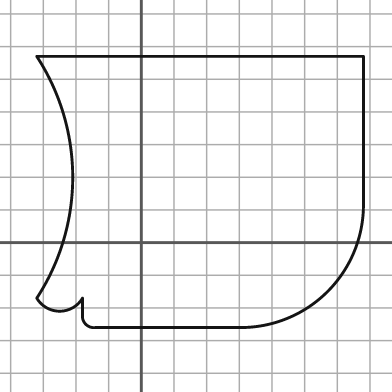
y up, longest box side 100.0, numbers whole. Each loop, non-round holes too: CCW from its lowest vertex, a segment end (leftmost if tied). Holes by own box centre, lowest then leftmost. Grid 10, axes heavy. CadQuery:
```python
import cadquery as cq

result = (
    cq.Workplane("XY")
    .moveTo(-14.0, -26.0)
    .lineTo(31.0, -26.0)
    .threePointArc((57.0, -15.0), (68.0, 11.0))
    .lineTo(68.0, 57.0)
    .lineTo(-32.0, 57.0)
    .threePointArc((-21.0, 20.0), (-32.0, -17.0))
    .threePointArc((-25.0, -21.0), (-18.0, -17.0))
    .lineTo(-18.0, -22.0)
    .threePointArc((-17.0, -25.0), (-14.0, -26.0))
    .close()
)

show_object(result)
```